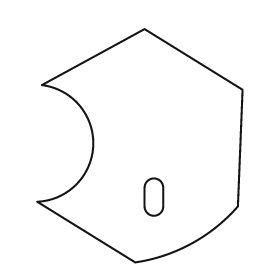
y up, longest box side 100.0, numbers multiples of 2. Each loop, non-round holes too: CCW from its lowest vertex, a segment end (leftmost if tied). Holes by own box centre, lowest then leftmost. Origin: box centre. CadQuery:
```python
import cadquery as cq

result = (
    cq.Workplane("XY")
    .moveTo(-2.0, -50.0)
    .threePointArc((22.0, -42.0), (42.0, -26.0))
    .lineTo(44.0, 24.0)
    .lineTo(2.0, 50.0)
    .lineTo(-42.0, 26.0)
    .threePointArc((-20.0, 0.0), (-44.0, -24.0))
    .close()
    .moveTo(2.0, -26.0)
    .threePointArc((6.0, -30.0), (10.0, -26.0))
    .lineTo(10.0, -18.0)
    .threePointArc((6.0, -14.0), (2.0, -18.0))
    .close()
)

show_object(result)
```